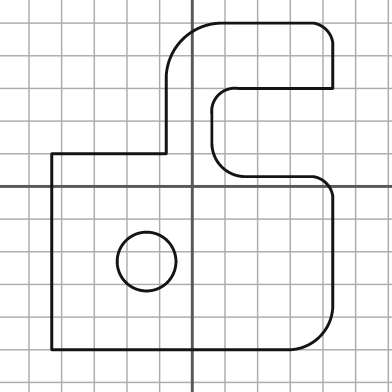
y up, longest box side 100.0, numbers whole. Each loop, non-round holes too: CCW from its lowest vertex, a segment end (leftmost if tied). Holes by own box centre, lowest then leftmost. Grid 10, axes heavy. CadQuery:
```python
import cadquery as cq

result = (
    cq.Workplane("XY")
    .moveTo(-43.0, -50.0)
    .lineTo(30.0, -50.0)
    .threePointArc((39.0, -46.0), (43.0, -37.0))
    .lineTo(43.0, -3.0)
    .threePointArc((41.0, 1.0), (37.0, 3.0))
    .lineTo(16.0, 3.0)
    .threePointArc((9.0, 6.0), (6.0, 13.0))
    .lineTo(6.0, 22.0)
    .threePointArc((8.0, 28.0), (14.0, 30.0))
    .lineTo(43.0, 30.0)
    .lineTo(43.0, 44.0)
    .threePointArc((41.0, 48.0), (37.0, 50.0))
    .lineTo(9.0, 50.0)
    .threePointArc((-3.0, 45.0), (-8.0, 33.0))
    .lineTo(-8.0, 10.0)
    .lineTo(-43.0, 10.0)
    .close()
    .moveTo(-14.0, -23.0)
    .circle(9.0)
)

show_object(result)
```